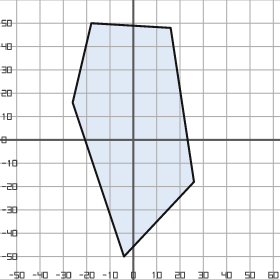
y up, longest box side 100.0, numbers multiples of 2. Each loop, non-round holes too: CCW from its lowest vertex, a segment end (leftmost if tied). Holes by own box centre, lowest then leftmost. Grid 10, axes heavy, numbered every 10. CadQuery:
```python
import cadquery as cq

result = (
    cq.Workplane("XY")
    .moveTo(-4.0, -50.0)
    .lineTo(26.0, -18.0)
    .lineTo(16.0, 48.0)
    .lineTo(-18.0, 50.0)
    .lineTo(-26.0, 16.0)
    .close()
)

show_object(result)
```